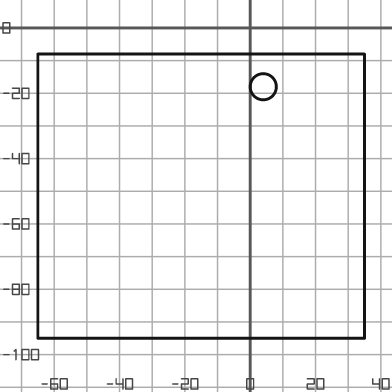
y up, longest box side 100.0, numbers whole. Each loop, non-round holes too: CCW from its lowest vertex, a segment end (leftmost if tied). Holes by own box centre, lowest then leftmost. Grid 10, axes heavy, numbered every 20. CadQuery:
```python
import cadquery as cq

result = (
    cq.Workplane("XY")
    .moveTo(-65.0, -95.0)
    .lineTo(35.0, -95.0)
    .lineTo(35.0, -8.0)
    .lineTo(-65.0, -8.0)
    .close()
    .moveTo(4.0, -18.0)
    .circle(4.0)
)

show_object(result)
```